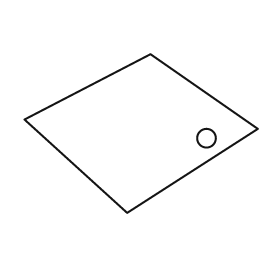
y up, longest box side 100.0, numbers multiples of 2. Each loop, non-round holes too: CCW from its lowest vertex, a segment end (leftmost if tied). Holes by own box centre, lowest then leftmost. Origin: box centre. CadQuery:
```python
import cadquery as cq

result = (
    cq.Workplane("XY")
    .moveTo(-6.0, -34.0)
    .lineTo(50.0, 2.0)
    .lineTo(4.0, 34.0)
    .lineTo(-50.0, 6.0)
    .close()
    .moveTo(28.0, -2.0)
    .circle(4.0)
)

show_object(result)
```